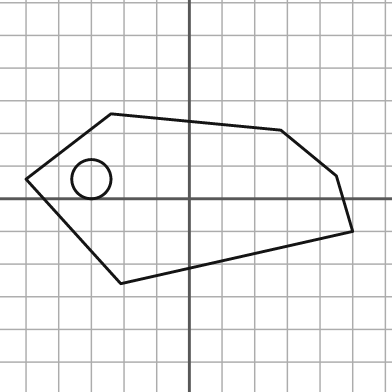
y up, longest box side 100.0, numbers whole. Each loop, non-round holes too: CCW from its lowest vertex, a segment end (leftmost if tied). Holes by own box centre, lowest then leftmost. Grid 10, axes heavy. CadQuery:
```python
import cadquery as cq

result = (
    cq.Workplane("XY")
    .moveTo(-21.0, -26.0)
    .lineTo(50.0, -10.0)
    .lineTo(45.0, 7.0)
    .lineTo(28.0, 21.0)
    .lineTo(-24.0, 26.0)
    .lineTo(-50.0, 6.0)
    .close()
    .moveTo(-30.0, 6.0)
    .circle(6.0)
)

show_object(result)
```